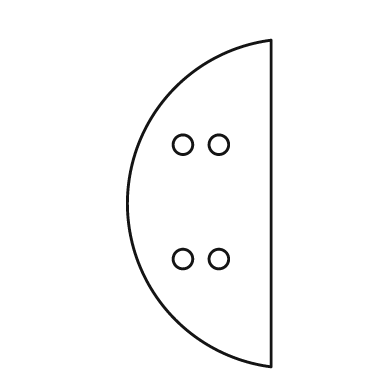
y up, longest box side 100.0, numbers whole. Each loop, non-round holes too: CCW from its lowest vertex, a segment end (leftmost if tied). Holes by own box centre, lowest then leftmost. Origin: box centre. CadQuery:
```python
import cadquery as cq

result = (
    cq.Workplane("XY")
    .moveTo(22.0, -50.0)
    .lineTo(22.0, 50.0)
    .threePointArc((-22.0, 0.0), (22.0, -50.0))
    .close()
    .moveTo(-5.0, -17.0)
    .circle(3.0)
    .moveTo(6.0, -17.0)
    .circle(3.0)
    .moveTo(-5.0, 18.0)
    .circle(3.0)
    .moveTo(6.0, 18.0)
    .circle(3.0)
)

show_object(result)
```